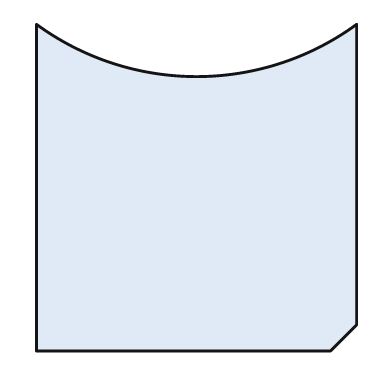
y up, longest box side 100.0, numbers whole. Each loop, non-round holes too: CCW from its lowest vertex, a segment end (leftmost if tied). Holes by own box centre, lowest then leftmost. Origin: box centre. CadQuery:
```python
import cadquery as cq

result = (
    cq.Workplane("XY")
    .moveTo(-49.0, -50.0)
    .lineTo(41.0, -50.0)
    .lineTo(49.0, -42.0)
    .lineTo(49.0, 50.0)
    .threePointArc((0.0, 34.0), (-49.0, 50.0))
    .close()
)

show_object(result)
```